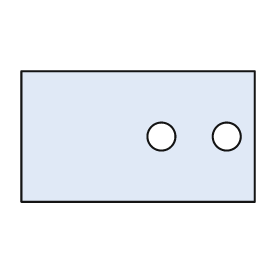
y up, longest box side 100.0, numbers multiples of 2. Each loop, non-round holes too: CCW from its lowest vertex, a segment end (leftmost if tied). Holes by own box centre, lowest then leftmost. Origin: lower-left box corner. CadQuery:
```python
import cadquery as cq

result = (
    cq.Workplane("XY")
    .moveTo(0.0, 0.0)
    .lineTo(100.0, 0.0)
    .lineTo(100.0, 56.0)
    .lineTo(0.0, 56.0)
    .close()
    .moveTo(60.0, 28.0)
    .circle(6.0)
    .moveTo(88.0, 28.0)
    .circle(6.0)
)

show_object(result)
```